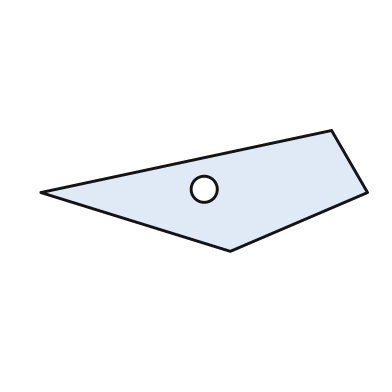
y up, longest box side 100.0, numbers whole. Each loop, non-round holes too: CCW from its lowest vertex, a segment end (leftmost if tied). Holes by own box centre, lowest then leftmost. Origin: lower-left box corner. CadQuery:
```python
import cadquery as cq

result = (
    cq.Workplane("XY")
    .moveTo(58.0, 0.0)
    .lineTo(100.0, 18.0)
    .lineTo(89.0, 37.0)
    .lineTo(0.0, 18.0)
    .close()
    .moveTo(50.0, 19.0)
    .circle(4.0)
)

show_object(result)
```